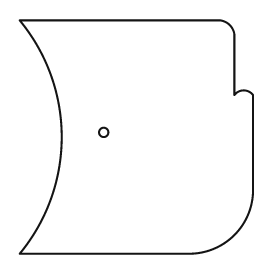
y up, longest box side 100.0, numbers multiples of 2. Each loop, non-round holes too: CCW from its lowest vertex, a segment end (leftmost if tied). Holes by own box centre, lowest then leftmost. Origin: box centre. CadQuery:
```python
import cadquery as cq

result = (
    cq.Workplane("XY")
    .moveTo(-50.0, -50.0)
    .lineTo(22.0, -50.0)
    .threePointArc((42.0, -42.0), (50.0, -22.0))
    .lineTo(50.0, 18.0)
    .threePointArc((46.0, 20.0), (42.0, 18.0))
    .lineTo(42.0, 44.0)
    .threePointArc((40.0, 48.0), (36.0, 50.0))
    .lineTo(-50.0, 50.0)
    .threePointArc((-32.0, 0.0), (-50.0, -50.0))
    .close()
    .moveTo(-14.0, 2.0)
    .circle(2.0)
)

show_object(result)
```